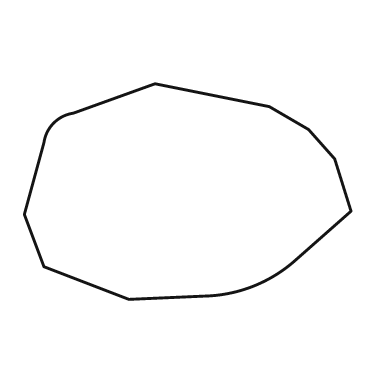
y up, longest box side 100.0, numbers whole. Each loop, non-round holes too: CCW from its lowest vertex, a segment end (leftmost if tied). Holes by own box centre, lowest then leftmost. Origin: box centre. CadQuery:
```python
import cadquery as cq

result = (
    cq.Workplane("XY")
    .moveTo(-18.0, -33.0)
    .lineTo(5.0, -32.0)
    .threePointArc((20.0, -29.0), (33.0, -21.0))
    .lineTo(50.0, -6.0)
    .lineTo(45.0, 10.0)
    .lineTo(37.0, 19.0)
    .lineTo(25.0, 26.0)
    .lineTo(-10.0, 33.0)
    .lineTo(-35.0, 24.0)
    .threePointArc((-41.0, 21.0), (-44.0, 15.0))
    .lineTo(-50.0, -7.0)
    .lineTo(-44.0, -23.0)
    .close()
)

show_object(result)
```